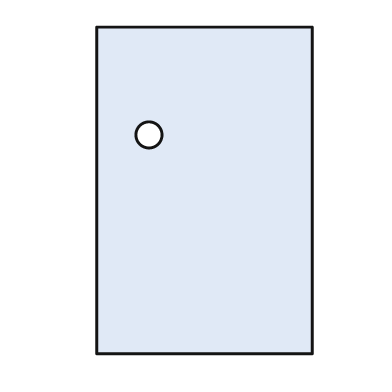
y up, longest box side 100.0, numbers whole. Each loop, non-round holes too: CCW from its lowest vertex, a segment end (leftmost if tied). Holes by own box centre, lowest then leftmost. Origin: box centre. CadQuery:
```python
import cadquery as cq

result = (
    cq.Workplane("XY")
    .moveTo(-33.0, -50.0)
    .lineTo(33.0, -50.0)
    .lineTo(33.0, 50.0)
    .lineTo(-33.0, 50.0)
    .close()
    .moveTo(-17.0, 17.0)
    .circle(4.0)
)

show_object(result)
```